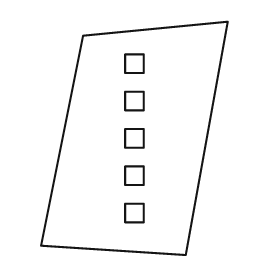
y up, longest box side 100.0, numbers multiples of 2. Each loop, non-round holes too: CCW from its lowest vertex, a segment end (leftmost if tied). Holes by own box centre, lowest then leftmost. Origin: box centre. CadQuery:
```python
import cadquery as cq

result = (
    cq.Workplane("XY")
    .moveTo(22.0, -50.0)
    .lineTo(40.0, 50.0)
    .lineTo(-22.0, 44.0)
    .lineTo(-40.0, -46.0)
    .close()
    .moveTo(-4.0, -36.0)
    .lineTo(4.0, -36.0)
    .lineTo(4.0, -28.0)
    .lineTo(-4.0, -28.0)
    .close()
    .moveTo(-4.0, -20.0)
    .lineTo(4.0, -20.0)
    .lineTo(4.0, -12.0)
    .lineTo(-4.0, -12.0)
    .close()
    .moveTo(-4.0, -4.0)
    .lineTo(4.0, -4.0)
    .lineTo(4.0, 4.0)
    .lineTo(-4.0, 4.0)
    .close()
    .moveTo(-4.0, 12.0)
    .lineTo(4.0, 12.0)
    .lineTo(4.0, 20.0)
    .lineTo(-4.0, 20.0)
    .close()
    .moveTo(-4.0, 28.0)
    .lineTo(4.0, 28.0)
    .lineTo(4.0, 36.0)
    .lineTo(-4.0, 36.0)
    .close()
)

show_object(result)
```